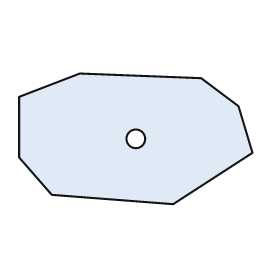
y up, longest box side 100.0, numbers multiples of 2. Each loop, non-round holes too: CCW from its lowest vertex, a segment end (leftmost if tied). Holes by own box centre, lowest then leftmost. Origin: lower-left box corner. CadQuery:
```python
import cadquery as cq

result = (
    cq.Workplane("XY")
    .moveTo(66.0, 0.0)
    .lineTo(100.0, 22.0)
    .lineTo(94.0, 42.0)
    .lineTo(78.0, 54.0)
    .lineTo(26.0, 56.0)
    .lineTo(0.0, 46.0)
    .lineTo(0.0, 20.0)
    .lineTo(14.0, 4.0)
    .close()
    .moveTo(50.0, 28.0)
    .circle(4.0)
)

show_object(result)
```